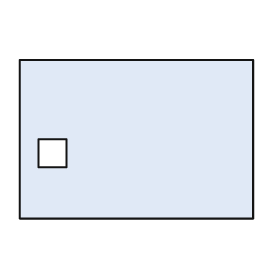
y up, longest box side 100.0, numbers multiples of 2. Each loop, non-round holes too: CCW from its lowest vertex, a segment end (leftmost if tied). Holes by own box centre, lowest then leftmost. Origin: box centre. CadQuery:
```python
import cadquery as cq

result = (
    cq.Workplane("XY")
    .moveTo(-50.0, -34.0)
    .lineTo(50.0, -34.0)
    .lineTo(50.0, 34.0)
    .lineTo(-50.0, 34.0)
    .close()
    .moveTo(-42.0, -12.0)
    .lineTo(-30.0, -12.0)
    .lineTo(-30.0, 0.0)
    .lineTo(-42.0, 0.0)
    .close()
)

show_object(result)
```